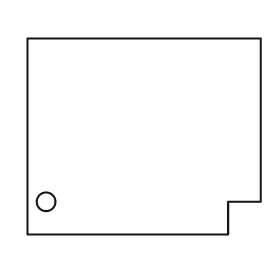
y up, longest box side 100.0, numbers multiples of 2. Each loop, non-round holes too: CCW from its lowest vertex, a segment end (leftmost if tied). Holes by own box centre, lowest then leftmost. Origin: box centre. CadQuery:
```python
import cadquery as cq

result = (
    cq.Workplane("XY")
    .moveTo(-50.0, -42.0)
    .lineTo(36.0, -42.0)
    .lineTo(36.0, -28.0)
    .lineTo(50.0, -28.0)
    .lineTo(50.0, 42.0)
    .lineTo(-50.0, 42.0)
    .close()
    .moveTo(-42.0, -28.0)
    .circle(4.0)
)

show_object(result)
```